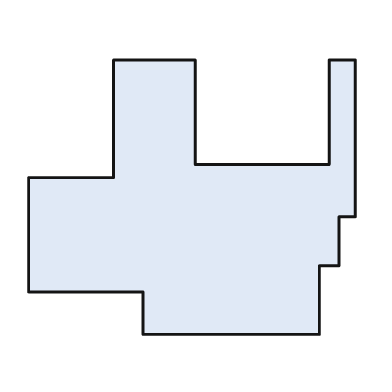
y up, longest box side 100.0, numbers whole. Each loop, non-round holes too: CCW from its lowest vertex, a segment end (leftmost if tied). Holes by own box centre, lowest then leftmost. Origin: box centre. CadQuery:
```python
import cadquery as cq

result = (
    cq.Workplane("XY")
    .moveTo(-15.0, -42.0)
    .lineTo(39.0, -42.0)
    .lineTo(39.0, -21.0)
    .lineTo(45.0, -21.0)
    .lineTo(45.0, -6.0)
    .lineTo(50.0, -6.0)
    .lineTo(50.0, 42.0)
    .lineTo(42.0, 42.0)
    .lineTo(42.0, 10.0)
    .lineTo(1.0, 10.0)
    .lineTo(1.0, 42.0)
    .lineTo(-24.0, 42.0)
    .lineTo(-24.0, 6.0)
    .lineTo(-50.0, 6.0)
    .lineTo(-50.0, -29.0)
    .lineTo(-15.0, -29.0)
    .close()
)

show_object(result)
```